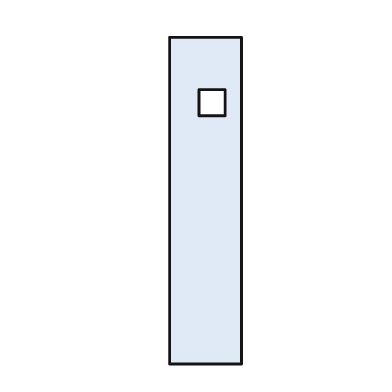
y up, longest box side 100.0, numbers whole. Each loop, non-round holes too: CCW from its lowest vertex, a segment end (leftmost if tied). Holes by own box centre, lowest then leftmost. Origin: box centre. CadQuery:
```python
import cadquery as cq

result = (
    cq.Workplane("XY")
    .moveTo(-11.0, -50.0)
    .lineTo(11.0, -50.0)
    .lineTo(11.0, 50.0)
    .lineTo(-11.0, 50.0)
    .close()
    .moveTo(-2.0, 26.0)
    .lineTo(6.0, 26.0)
    .lineTo(6.0, 34.0)
    .lineTo(-2.0, 34.0)
    .close()
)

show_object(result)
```